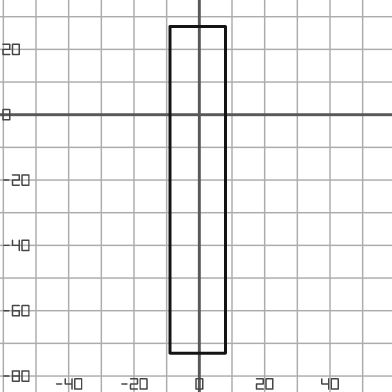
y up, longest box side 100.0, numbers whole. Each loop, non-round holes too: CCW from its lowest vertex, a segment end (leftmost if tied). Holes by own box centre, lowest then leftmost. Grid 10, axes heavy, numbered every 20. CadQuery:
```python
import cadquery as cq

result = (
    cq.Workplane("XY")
    .moveTo(-9.0, -73.0)
    .lineTo(8.0, -73.0)
    .lineTo(8.0, 27.0)
    .lineTo(-9.0, 27.0)
    .close()
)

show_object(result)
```